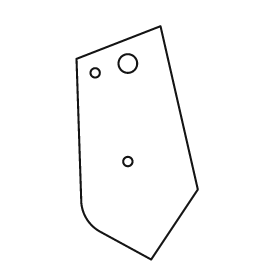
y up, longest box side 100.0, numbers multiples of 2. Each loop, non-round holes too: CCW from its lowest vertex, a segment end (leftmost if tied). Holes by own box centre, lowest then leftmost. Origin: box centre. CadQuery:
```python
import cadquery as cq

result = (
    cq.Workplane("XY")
    .moveTo(6.0, -50.0)
    .lineTo(26.0, -20.0)
    .lineTo(10.0, 50.0)
    .lineTo(-26.0, 36.0)
    .lineTo(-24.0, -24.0)
    .threePointArc((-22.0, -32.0), (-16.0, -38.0))
    .close()
    .moveTo(-4.0, -8.0)
    .circle(2.0)
    .moveTo(-18.0, 30.0)
    .circle(2.0)
    .moveTo(-4.0, 34.0)
    .circle(4.0)
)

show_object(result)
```